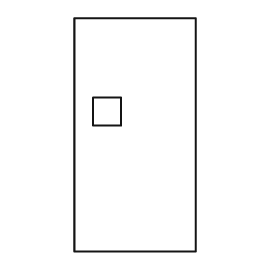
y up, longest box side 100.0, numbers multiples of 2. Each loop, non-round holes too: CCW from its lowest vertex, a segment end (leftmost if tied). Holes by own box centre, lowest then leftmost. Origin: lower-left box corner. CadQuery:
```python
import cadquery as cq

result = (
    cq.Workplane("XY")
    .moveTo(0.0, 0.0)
    .lineTo(52.0, 0.0)
    .lineTo(52.0, 100.0)
    .lineTo(0.0, 100.0)
    .close()
    .moveTo(8.0, 54.0)
    .lineTo(20.0, 54.0)
    .lineTo(20.0, 66.0)
    .lineTo(8.0, 66.0)
    .close()
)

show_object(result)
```